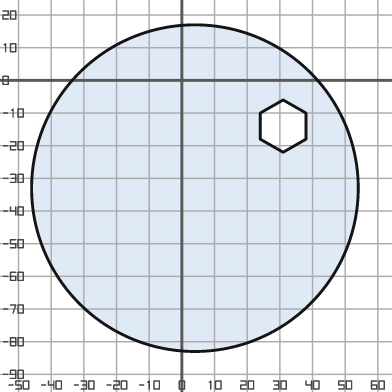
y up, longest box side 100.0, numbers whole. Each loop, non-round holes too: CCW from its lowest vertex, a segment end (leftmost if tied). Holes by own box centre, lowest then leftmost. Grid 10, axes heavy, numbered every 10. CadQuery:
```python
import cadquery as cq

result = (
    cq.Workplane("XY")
    .moveTo(4.0, -33.0)
    .circle(50.0)
    .moveTo(31.0, -22.0)
    .lineTo(38.0, -18.0)
    .lineTo(38.0, -10.0)
    .lineTo(31.0, -6.0)
    .lineTo(24.0, -10.0)
    .lineTo(24.0, -18.0)
    .close()
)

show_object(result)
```